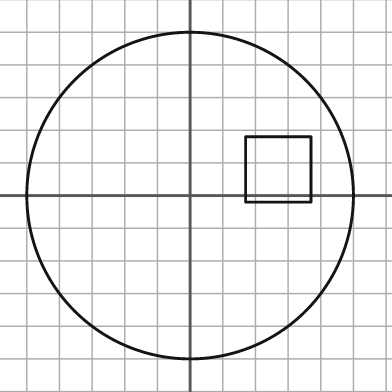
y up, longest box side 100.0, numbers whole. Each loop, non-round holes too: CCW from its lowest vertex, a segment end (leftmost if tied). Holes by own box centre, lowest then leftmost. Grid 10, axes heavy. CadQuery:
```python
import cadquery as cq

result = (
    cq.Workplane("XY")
    .moveTo(0.0, 0.0)
    .circle(50.0)
    .moveTo(17.0, -2.0)
    .lineTo(37.0, -2.0)
    .lineTo(37.0, 18.0)
    .lineTo(17.0, 18.0)
    .close()
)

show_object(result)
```